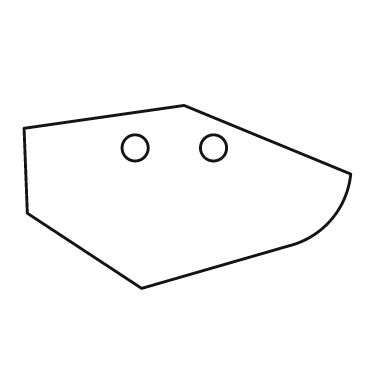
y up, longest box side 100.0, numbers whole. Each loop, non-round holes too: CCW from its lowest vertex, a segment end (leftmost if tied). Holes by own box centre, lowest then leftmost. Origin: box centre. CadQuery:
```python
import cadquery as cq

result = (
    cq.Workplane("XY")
    .moveTo(-14.0, -28.0)
    .lineTo(31.0, -15.0)
    .threePointArc((44.0, -7.0), (50.0, 7.0))
    .lineTo(-1.0, 28.0)
    .lineTo(-50.0, 21.0)
    .lineTo(-49.0, -5.0)
    .close()
    .moveTo(-16.0, 15.0)
    .circle(4.0)
    .moveTo(8.0, 15.0)
    .circle(4.0)
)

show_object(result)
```